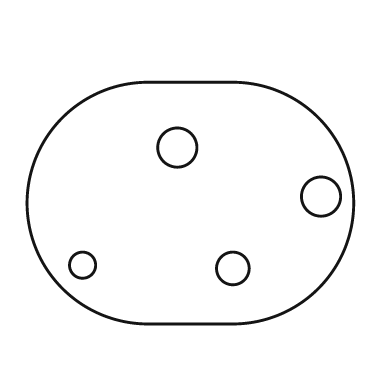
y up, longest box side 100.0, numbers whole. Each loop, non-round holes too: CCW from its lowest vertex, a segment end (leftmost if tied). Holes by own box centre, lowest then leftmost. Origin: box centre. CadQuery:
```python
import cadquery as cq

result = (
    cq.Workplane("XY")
    .moveTo(-13.0, -37.0)
    .lineTo(13.0, -37.0)
    .threePointArc((50.0, 0.0), (13.0, 37.0))
    .lineTo(-13.0, 37.0)
    .threePointArc((-50.0, 0.0), (-13.0, -37.0))
    .close()
    .moveTo(13.0, -20.0)
    .circle(5.0)
    .moveTo(-33.0, -19.0)
    .circle(4.0)
    .moveTo(40.0, 2.0)
    .circle(6.0)
    .moveTo(-4.0, 17.0)
    .circle(6.0)
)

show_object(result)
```